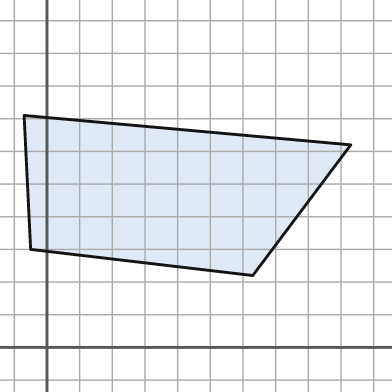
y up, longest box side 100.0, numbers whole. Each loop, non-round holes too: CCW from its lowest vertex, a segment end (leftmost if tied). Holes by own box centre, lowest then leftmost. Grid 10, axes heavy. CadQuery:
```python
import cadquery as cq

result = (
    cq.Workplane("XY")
    .moveTo(63.0, 22.0)
    .lineTo(93.0, 62.0)
    .lineTo(-7.0, 71.0)
    .lineTo(-5.0, 30.0)
    .close()
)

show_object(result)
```